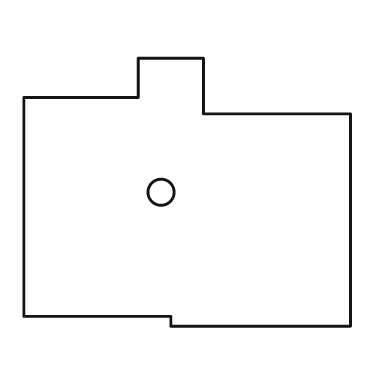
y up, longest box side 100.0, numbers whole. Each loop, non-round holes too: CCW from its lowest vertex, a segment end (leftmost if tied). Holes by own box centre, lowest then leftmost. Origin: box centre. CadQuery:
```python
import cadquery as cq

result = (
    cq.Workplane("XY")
    .moveTo(-5.0, -41.0)
    .lineTo(50.0, -41.0)
    .lineTo(50.0, 24.0)
    .lineTo(5.0, 24.0)
    .lineTo(5.0, 41.0)
    .lineTo(-15.0, 41.0)
    .lineTo(-15.0, 29.0)
    .lineTo(-50.0, 29.0)
    .lineTo(-50.0, -38.0)
    .lineTo(-5.0, -38.0)
    .close()
    .moveTo(-8.0, 0.0)
    .circle(4.0)
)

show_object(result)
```